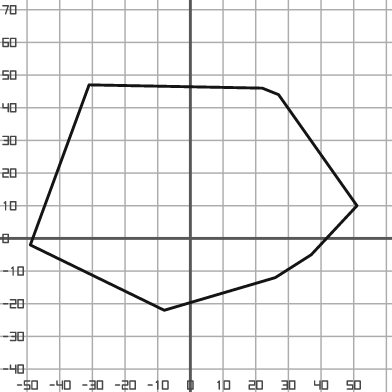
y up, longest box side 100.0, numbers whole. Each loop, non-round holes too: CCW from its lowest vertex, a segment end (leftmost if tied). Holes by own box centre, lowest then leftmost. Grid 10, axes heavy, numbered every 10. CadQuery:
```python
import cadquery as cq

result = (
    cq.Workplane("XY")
    .moveTo(-8.0, -22.0)
    .lineTo(26.0, -12.0)
    .lineTo(37.0, -5.0)
    .lineTo(51.0, 10.0)
    .lineTo(27.0, 44.0)
    .lineTo(22.0, 46.0)
    .lineTo(-31.0, 47.0)
    .lineTo(-49.0, -2.0)
    .close()
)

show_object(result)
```